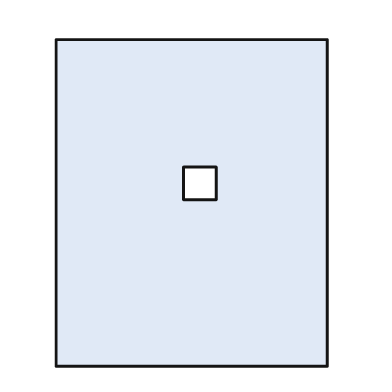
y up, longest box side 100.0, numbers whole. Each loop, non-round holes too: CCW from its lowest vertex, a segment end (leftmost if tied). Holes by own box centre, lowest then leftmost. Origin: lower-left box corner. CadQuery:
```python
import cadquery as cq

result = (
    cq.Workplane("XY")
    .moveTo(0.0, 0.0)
    .lineTo(83.0, 0.0)
    .lineTo(83.0, 100.0)
    .lineTo(0.0, 100.0)
    .close()
    .moveTo(39.0, 51.0)
    .lineTo(49.0, 51.0)
    .lineTo(49.0, 61.0)
    .lineTo(39.0, 61.0)
    .close()
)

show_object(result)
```